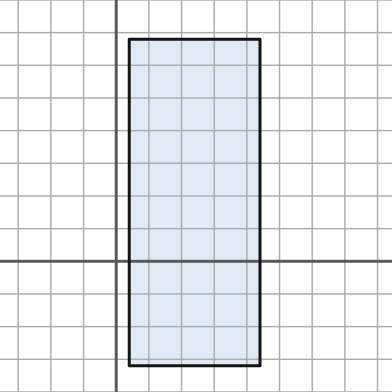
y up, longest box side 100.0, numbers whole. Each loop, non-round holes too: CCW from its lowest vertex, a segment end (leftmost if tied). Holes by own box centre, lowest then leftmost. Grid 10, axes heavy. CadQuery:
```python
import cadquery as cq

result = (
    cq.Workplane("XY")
    .moveTo(4.0, -32.0)
    .lineTo(44.0, -32.0)
    .lineTo(44.0, 68.0)
    .lineTo(4.0, 68.0)
    .close()
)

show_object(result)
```